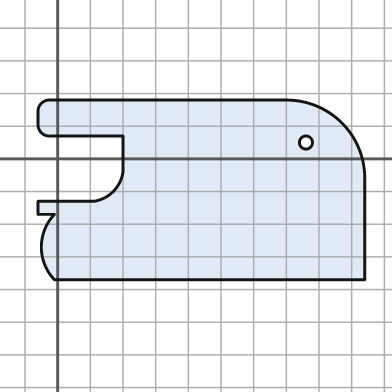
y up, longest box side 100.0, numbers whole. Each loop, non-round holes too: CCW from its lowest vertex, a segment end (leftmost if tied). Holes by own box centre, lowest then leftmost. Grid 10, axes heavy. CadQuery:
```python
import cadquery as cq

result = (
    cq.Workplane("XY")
    .moveTo(-1.0, -37.0)
    .lineTo(94.0, -37.0)
    .lineTo(94.0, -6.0)
    .threePointArc((87.0, 11.0), (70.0, 18.0))
    .lineTo(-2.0, 18.0)
    .threePointArc((-5.0, 17.0), (-6.0, 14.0))
    .lineTo(-6.0, 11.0)
    .threePointArc((-5.0, 8.0), (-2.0, 7.0))
    .lineTo(20.0, 7.0)
    .lineTo(20.0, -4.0)
    .threePointArc((17.0, -10.0), (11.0, -13.0))
    .lineTo(-6.0, -13.0)
    .lineTo(-6.0, -17.0)
    .lineTo(-1.0, -17.0)
    .threePointArc((-5.0, -27.0), (-1.0, -37.0))
    .close()
    .moveTo(76.0, 5.0)
    .circle(2.0)
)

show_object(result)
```